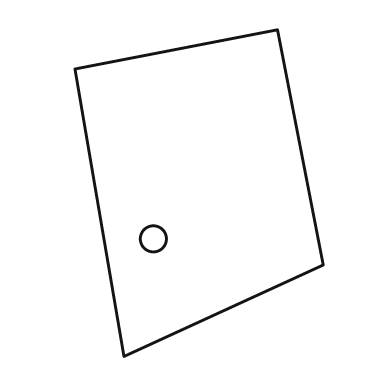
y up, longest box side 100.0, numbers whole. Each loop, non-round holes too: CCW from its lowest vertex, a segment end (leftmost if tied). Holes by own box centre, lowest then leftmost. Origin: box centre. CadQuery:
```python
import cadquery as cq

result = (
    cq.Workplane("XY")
    .moveTo(-23.0, -50.0)
    .lineTo(38.0, -22.0)
    .lineTo(24.0, 50.0)
    .lineTo(-38.0, 38.0)
    .close()
    .moveTo(-14.0, -14.0)
    .circle(4.0)
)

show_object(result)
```